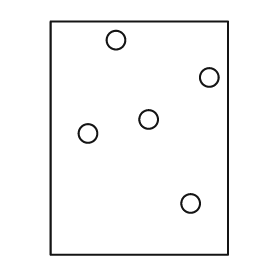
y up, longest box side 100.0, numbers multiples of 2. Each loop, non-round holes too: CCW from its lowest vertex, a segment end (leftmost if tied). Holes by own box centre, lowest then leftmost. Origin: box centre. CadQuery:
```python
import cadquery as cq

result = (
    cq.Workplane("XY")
    .moveTo(-38.0, -50.0)
    .lineTo(38.0, -50.0)
    .lineTo(38.0, 50.0)
    .lineTo(-38.0, 50.0)
    .close()
    .moveTo(22.0, -28.0)
    .circle(4.0)
    .moveTo(-22.0, 2.0)
    .circle(4.0)
    .moveTo(4.0, 8.0)
    .circle(4.0)
    .moveTo(30.0, 26.0)
    .circle(4.0)
    .moveTo(-10.0, 42.0)
    .circle(4.0)
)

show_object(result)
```